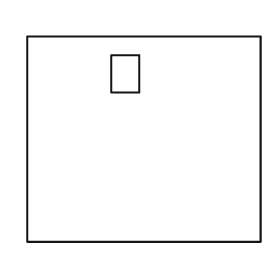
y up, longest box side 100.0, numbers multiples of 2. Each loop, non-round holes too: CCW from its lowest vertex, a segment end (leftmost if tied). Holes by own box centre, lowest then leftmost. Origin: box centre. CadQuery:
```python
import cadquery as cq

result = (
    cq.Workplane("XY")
    .moveTo(-50.0, -44.0)
    .lineTo(50.0, -44.0)
    .lineTo(50.0, 44.0)
    .lineTo(-50.0, 44.0)
    .close()
    .moveTo(-14.0, 20.0)
    .lineTo(-2.0, 20.0)
    .lineTo(-2.0, 36.0)
    .lineTo(-14.0, 36.0)
    .close()
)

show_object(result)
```